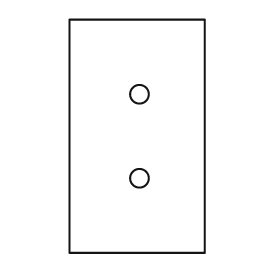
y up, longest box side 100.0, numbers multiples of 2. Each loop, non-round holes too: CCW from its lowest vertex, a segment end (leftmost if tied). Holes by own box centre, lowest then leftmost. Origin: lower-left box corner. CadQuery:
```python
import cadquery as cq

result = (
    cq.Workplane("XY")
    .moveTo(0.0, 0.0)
    .lineTo(58.0, 0.0)
    .lineTo(58.0, 100.0)
    .lineTo(0.0, 100.0)
    .close()
    .moveTo(30.0, 32.0)
    .circle(4.0)
    .moveTo(30.0, 68.0)
    .circle(4.0)
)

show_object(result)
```